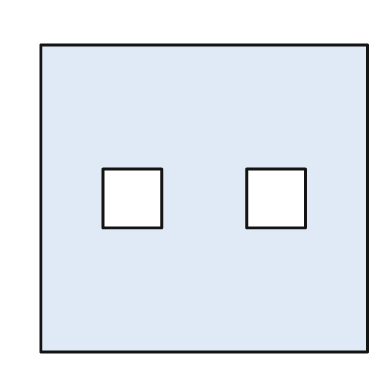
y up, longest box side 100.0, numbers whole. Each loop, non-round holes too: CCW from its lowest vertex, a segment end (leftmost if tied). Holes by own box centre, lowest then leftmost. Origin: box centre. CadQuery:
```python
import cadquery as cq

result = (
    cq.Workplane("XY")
    .moveTo(-50.0, -47.0)
    .lineTo(50.0, -47.0)
    .lineTo(50.0, 47.0)
    .lineTo(-50.0, 47.0)
    .close()
    .moveTo(-31.0, -9.0)
    .lineTo(-13.0, -9.0)
    .lineTo(-13.0, 9.0)
    .lineTo(-31.0, 9.0)
    .close()
    .moveTo(13.0, -9.0)
    .lineTo(31.0, -9.0)
    .lineTo(31.0, 9.0)
    .lineTo(13.0, 9.0)
    .close()
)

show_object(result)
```